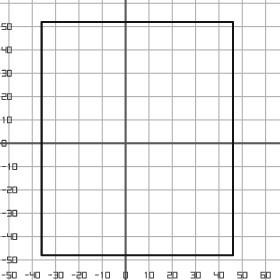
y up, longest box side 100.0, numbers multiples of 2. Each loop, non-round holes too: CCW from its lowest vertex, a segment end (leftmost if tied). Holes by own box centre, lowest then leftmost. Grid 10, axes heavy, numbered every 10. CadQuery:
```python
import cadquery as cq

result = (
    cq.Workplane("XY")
    .moveTo(-36.0, -48.0)
    .lineTo(46.0, -48.0)
    .lineTo(46.0, 52.0)
    .lineTo(-36.0, 52.0)
    .close()
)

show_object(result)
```